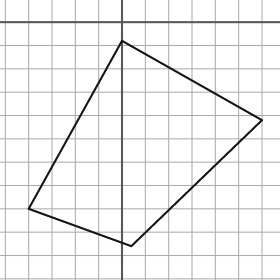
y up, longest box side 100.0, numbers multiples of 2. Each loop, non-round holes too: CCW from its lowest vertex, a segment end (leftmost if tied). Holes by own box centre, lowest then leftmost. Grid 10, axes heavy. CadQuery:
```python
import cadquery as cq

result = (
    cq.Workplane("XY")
    .moveTo(4.0, -96.0)
    .lineTo(60.0, -42.0)
    .lineTo(0.0, -8.0)
    .lineTo(-40.0, -80.0)
    .close()
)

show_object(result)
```